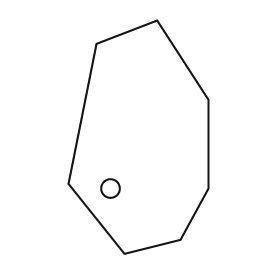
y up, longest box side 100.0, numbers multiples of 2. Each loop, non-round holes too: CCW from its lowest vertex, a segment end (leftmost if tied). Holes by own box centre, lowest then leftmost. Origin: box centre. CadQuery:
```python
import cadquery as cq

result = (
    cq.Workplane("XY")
    .moveTo(-6.0, -50.0)
    .lineTo(18.0, -44.0)
    .lineTo(30.0, -22.0)
    .lineTo(30.0, 16.0)
    .lineTo(8.0, 50.0)
    .lineTo(-18.0, 40.0)
    .lineTo(-30.0, -20.0)
    .close()
    .moveTo(-12.0, -22.0)
    .circle(4.0)
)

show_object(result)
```